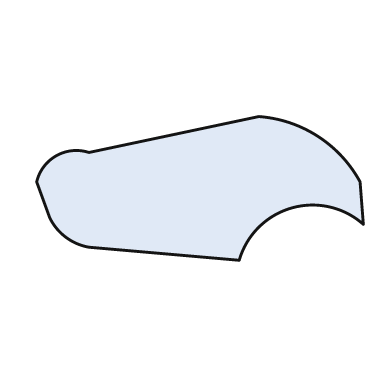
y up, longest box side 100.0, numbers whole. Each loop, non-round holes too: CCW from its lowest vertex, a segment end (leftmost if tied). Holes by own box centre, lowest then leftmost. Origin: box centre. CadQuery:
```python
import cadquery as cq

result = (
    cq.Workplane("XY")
    .moveTo(12.0, -22.0)
    .threePointArc((28.0, -6.0), (50.0, -11.0))
    .lineTo(49.0, 2.0)
    .threePointArc((36.0, 16.0), (18.0, 22.0))
    .lineTo(-34.0, 11.0)
    .threePointArc((-44.0, 10.0), (-50.0, 2.0))
    .lineTo(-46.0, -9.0)
    .threePointArc((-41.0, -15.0), (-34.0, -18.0))
    .close()
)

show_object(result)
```